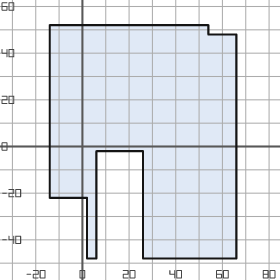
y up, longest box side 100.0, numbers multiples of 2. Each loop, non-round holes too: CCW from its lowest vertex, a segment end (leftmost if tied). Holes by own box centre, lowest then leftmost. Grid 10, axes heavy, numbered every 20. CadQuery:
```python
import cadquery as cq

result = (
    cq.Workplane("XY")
    .moveTo(2.0, -48.0)
    .lineTo(6.0, -48.0)
    .lineTo(6.0, -2.0)
    .lineTo(26.0, -2.0)
    .lineTo(26.0, -48.0)
    .lineTo(66.0, -48.0)
    .lineTo(66.0, 48.0)
    .lineTo(54.0, 48.0)
    .lineTo(54.0, 52.0)
    .lineTo(-14.0, 52.0)
    .lineTo(-14.0, -22.0)
    .lineTo(2.0, -22.0)
    .close()
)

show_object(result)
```